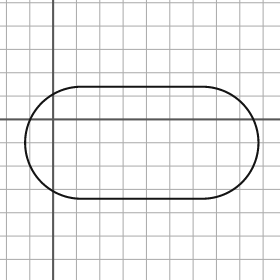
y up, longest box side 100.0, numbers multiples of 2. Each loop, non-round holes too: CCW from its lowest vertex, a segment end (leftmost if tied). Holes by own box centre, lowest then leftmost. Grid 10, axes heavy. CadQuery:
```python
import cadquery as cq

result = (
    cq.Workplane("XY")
    .moveTo(12.0, -34.0)
    .lineTo(64.0, -34.0)
    .threePointArc((88.0, -10.0), (64.0, 14.0))
    .lineTo(12.0, 14.0)
    .threePointArc((-12.0, -10.0), (12.0, -34.0))
    .close()
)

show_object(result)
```